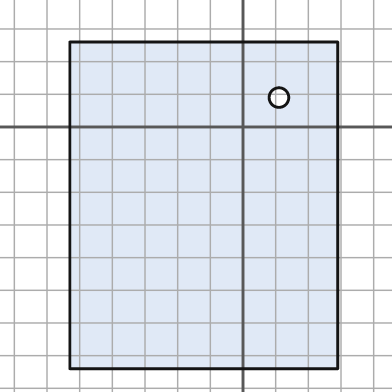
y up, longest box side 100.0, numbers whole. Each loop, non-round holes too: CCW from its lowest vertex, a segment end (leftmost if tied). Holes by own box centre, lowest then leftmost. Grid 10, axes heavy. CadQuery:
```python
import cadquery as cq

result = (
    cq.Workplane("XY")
    .moveTo(-53.0, -74.0)
    .lineTo(29.0, -74.0)
    .lineTo(29.0, 26.0)
    .lineTo(-53.0, 26.0)
    .close()
    .moveTo(11.0, 9.0)
    .circle(3.0)
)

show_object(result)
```